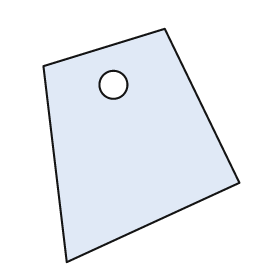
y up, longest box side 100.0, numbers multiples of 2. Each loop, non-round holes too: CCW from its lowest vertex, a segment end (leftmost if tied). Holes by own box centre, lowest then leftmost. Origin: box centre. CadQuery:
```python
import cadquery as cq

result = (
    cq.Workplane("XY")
    .moveTo(-32.0, -50.0)
    .lineTo(42.0, -16.0)
    .lineTo(10.0, 50.0)
    .lineTo(-42.0, 34.0)
    .close()
    .moveTo(-12.0, 26.0)
    .circle(6.0)
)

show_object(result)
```